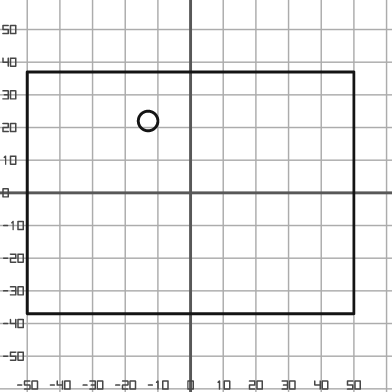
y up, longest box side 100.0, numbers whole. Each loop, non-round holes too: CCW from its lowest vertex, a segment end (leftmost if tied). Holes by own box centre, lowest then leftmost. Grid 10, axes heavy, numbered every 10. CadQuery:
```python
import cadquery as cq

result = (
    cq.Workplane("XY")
    .moveTo(-50.0, -37.0)
    .lineTo(50.0, -37.0)
    .lineTo(50.0, 37.0)
    .lineTo(-50.0, 37.0)
    .close()
    .moveTo(-13.0, 22.0)
    .circle(3.0)
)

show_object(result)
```